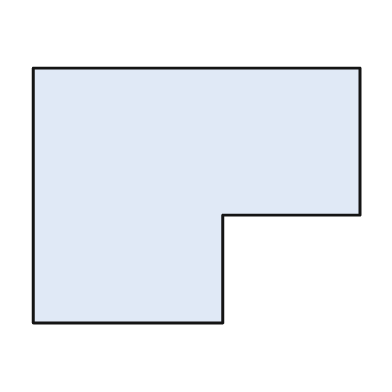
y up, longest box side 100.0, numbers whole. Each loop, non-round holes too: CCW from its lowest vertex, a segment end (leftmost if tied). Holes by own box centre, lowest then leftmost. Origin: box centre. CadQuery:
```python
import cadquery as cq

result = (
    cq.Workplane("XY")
    .moveTo(-50.0, -39.0)
    .lineTo(8.0, -39.0)
    .lineTo(8.0, -6.0)
    .lineTo(50.0, -6.0)
    .lineTo(50.0, 39.0)
    .lineTo(-50.0, 39.0)
    .close()
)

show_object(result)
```